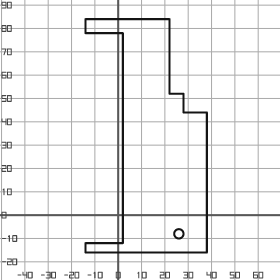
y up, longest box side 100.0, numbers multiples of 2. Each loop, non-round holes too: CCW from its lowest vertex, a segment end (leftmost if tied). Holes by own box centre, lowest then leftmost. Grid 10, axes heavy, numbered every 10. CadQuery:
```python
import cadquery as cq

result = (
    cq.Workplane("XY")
    .moveTo(-14.0, -16.0)
    .lineTo(38.0, -16.0)
    .lineTo(38.0, 44.0)
    .lineTo(28.0, 44.0)
    .lineTo(28.0, 52.0)
    .lineTo(22.0, 52.0)
    .lineTo(22.0, 84.0)
    .lineTo(-14.0, 84.0)
    .lineTo(-14.0, 78.0)
    .lineTo(2.0, 78.0)
    .lineTo(2.0, -12.0)
    .lineTo(-14.0, -12.0)
    .close()
    .moveTo(26.0, -8.0)
    .circle(2.0)
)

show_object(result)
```